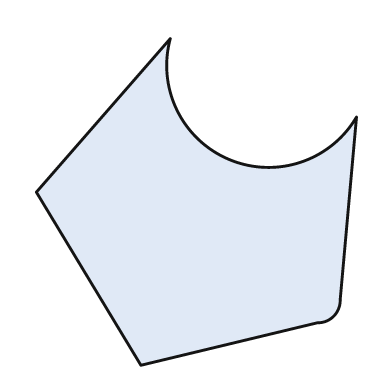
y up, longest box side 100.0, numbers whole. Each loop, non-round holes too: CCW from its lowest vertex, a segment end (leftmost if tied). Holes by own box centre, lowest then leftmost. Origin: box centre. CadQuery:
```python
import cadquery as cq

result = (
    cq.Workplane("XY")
    .moveTo(-17.0, -50.0)
    .lineTo(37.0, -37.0)
    .threePointArc((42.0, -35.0), (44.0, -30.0))
    .lineTo(49.0, 26.0)
    .threePointArc((10.0, 13.0), (-8.0, 50.0))
    .lineTo(-49.0, 3.0)
    .close()
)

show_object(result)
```